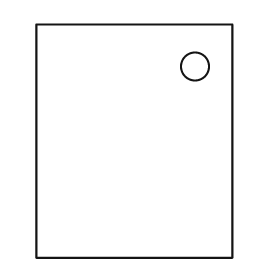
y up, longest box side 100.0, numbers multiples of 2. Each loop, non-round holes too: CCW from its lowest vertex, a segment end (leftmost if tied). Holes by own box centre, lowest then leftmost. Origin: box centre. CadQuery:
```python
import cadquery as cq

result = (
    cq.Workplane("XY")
    .moveTo(-42.0, -50.0)
    .lineTo(42.0, -50.0)
    .lineTo(42.0, 50.0)
    .lineTo(-42.0, 50.0)
    .close()
    .moveTo(26.0, 32.0)
    .circle(6.0)
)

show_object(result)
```